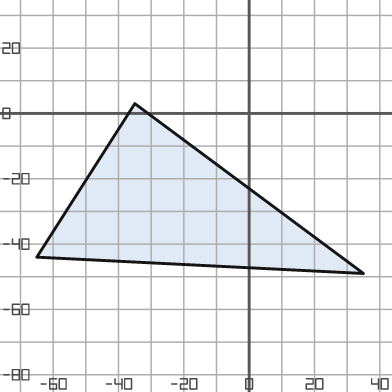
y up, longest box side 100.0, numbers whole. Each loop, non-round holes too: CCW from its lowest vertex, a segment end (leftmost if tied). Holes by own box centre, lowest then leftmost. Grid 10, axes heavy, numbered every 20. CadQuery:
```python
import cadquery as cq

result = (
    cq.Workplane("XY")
    .moveTo(35.0, -49.0)
    .lineTo(-35.0, 3.0)
    .lineTo(-65.0, -44.0)
    .close()
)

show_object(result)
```